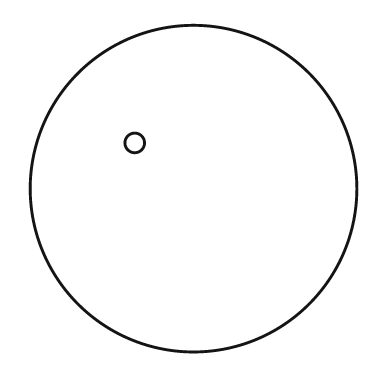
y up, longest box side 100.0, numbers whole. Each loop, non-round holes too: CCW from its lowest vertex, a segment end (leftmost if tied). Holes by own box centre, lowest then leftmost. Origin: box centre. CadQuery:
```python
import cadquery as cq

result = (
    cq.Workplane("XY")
    .moveTo(0.0, 0.0)
    .circle(50.0)
    .moveTo(-18.0, 14.0)
    .circle(3.0)
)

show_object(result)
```